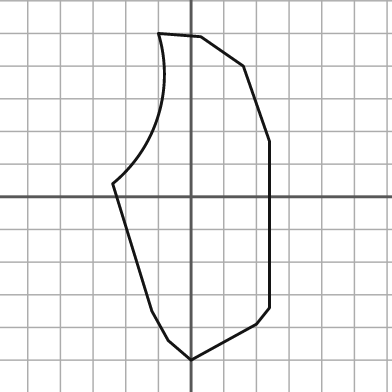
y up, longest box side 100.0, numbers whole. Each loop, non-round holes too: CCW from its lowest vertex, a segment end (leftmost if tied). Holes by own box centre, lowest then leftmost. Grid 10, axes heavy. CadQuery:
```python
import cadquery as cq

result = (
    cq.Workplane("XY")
    .moveTo(0.0, -50.0)
    .lineTo(20.0, -39.0)
    .lineTo(24.0, -34.0)
    .lineTo(24.0, 17.0)
    .lineTo(16.0, 40.0)
    .lineTo(3.0, 49.0)
    .lineTo(-10.0, 50.0)
    .threePointArc((-10.0, 25.0), (-24.0, 4.0))
    .lineTo(-12.0, -35.0)
    .lineTo(-7.0, -44.0)
    .close()
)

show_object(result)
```